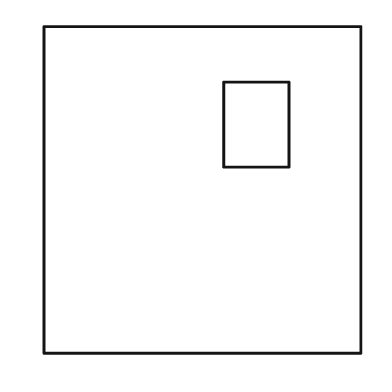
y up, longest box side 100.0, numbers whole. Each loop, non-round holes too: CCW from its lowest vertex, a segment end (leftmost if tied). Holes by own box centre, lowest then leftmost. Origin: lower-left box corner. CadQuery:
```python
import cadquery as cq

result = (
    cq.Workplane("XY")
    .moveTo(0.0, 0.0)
    .lineTo(97.0, 0.0)
    .lineTo(97.0, 100.0)
    .lineTo(0.0, 100.0)
    .close()
    .moveTo(55.0, 57.0)
    .lineTo(75.0, 57.0)
    .lineTo(75.0, 83.0)
    .lineTo(55.0, 83.0)
    .close()
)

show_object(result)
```